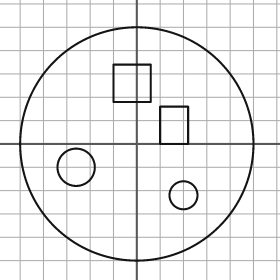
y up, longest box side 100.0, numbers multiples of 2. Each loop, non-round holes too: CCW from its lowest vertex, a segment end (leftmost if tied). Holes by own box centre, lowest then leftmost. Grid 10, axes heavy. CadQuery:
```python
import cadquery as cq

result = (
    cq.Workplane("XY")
    .moveTo(0.0, 0.0)
    .circle(50.0)
    .moveTo(20.0, -22.0)
    .circle(6.0)
    .moveTo(-26.0, -10.0)
    .circle(8.0)
    .moveTo(10.0, 0.0)
    .lineTo(22.0, 0.0)
    .lineTo(22.0, 16.0)
    .lineTo(10.0, 16.0)
    .close()
    .moveTo(-10.0, 18.0)
    .lineTo(6.0, 18.0)
    .lineTo(6.0, 34.0)
    .lineTo(-10.0, 34.0)
    .close()
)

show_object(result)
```